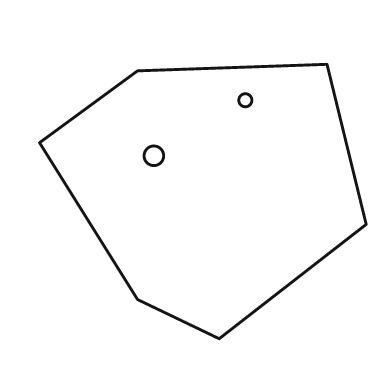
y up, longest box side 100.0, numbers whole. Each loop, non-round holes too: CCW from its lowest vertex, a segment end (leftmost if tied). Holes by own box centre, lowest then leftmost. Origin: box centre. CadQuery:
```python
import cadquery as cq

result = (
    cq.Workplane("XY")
    .moveTo(5.0, -42.0)
    .lineTo(50.0, -7.0)
    .lineTo(38.0, 42.0)
    .lineTo(-20.0, 40.0)
    .lineTo(-50.0, 18.0)
    .lineTo(-20.0, -30.0)
    .close()
    .moveTo(-15.0, 14.0)
    .circle(3.0)
    .moveTo(13.0, 31.0)
    .circle(2.0)
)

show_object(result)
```